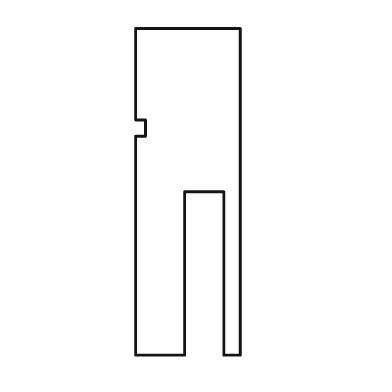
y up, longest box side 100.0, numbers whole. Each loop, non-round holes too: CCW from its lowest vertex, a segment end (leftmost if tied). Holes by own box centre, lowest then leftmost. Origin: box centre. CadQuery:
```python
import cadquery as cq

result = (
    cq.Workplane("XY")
    .moveTo(-16.0, -50.0)
    .lineTo(-1.0, -50.0)
    .lineTo(-1.0, 0.0)
    .lineTo(11.0, 0.0)
    .lineTo(11.0, -50.0)
    .lineTo(16.0, -50.0)
    .lineTo(16.0, 50.0)
    .lineTo(-16.0, 50.0)
    .lineTo(-16.0, 22.0)
    .lineTo(-13.0, 22.0)
    .lineTo(-13.0, 17.0)
    .lineTo(-16.0, 17.0)
    .close()
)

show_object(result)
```